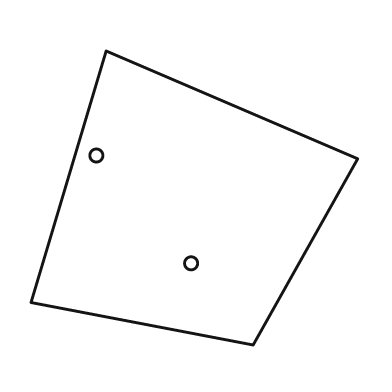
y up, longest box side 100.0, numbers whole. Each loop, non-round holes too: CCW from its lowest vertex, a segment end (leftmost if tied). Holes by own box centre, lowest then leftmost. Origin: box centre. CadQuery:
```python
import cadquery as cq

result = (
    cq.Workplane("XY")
    .moveTo(18.0, -45.0)
    .lineTo(50.0, 12.0)
    .lineTo(-27.0, 45.0)
    .lineTo(-50.0, -32.0)
    .close()
    .moveTo(-1.0, -20.0)
    .circle(2.0)
    .moveTo(-30.0, 13.0)
    .circle(2.0)
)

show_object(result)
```